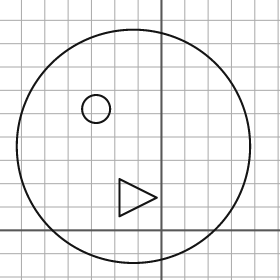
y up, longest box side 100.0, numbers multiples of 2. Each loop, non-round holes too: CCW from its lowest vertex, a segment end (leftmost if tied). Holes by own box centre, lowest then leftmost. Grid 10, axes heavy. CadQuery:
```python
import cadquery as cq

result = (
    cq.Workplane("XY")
    .moveTo(-12.0, 36.0)
    .circle(50.0)
    .moveTo(-18.0, 6.0)
    .lineTo(-2.0, 14.0)
    .lineTo(-18.0, 22.0)
    .close()
    .moveTo(-28.0, 52.0)
    .circle(6.0)
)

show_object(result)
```